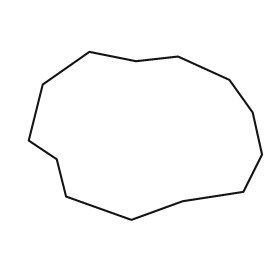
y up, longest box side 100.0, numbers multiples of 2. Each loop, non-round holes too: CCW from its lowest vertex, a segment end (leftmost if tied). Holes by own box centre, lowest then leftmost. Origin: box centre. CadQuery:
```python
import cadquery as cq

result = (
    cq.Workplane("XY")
    .moveTo(-6.0, -36.0)
    .lineTo(16.0, -28.0)
    .lineTo(42.0, -24.0)
    .lineTo(50.0, -8.0)
    .lineTo(46.0, 10.0)
    .lineTo(36.0, 24.0)
    .lineTo(14.0, 34.0)
    .lineTo(-4.0, 32.0)
    .lineTo(-24.0, 36.0)
    .lineTo(-44.0, 22.0)
    .lineTo(-50.0, -2.0)
    .lineTo(-38.0, -10.0)
    .lineTo(-34.0, -26.0)
    .close()
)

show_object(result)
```